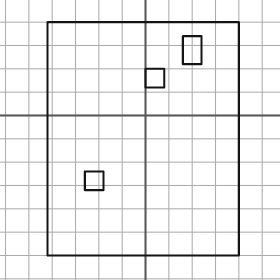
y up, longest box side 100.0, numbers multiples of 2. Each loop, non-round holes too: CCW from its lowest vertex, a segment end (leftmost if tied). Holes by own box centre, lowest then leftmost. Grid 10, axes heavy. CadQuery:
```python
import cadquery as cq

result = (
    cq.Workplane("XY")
    .moveTo(-42.0, -60.0)
    .lineTo(40.0, -60.0)
    .lineTo(40.0, 40.0)
    .lineTo(-42.0, 40.0)
    .close()
    .moveTo(-26.0, -32.0)
    .lineTo(-18.0, -32.0)
    .lineTo(-18.0, -24.0)
    .lineTo(-26.0, -24.0)
    .close()
    .moveTo(0.0, 12.0)
    .lineTo(8.0, 12.0)
    .lineTo(8.0, 20.0)
    .lineTo(0.0, 20.0)
    .close()
    .moveTo(16.0, 22.0)
    .lineTo(24.0, 22.0)
    .lineTo(24.0, 34.0)
    .lineTo(16.0, 34.0)
    .close()
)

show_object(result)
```